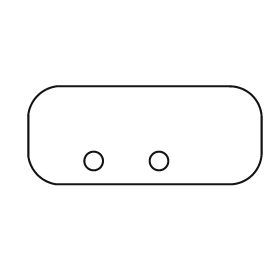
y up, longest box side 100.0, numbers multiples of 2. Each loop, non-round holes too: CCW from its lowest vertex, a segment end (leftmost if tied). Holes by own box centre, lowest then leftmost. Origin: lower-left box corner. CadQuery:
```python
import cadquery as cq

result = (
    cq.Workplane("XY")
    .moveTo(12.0, 0.0)
    .lineTo(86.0, 0.0)
    .threePointArc((96.0, 4.0), (100.0, 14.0))
    .lineTo(100.0, 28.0)
    .threePointArc((96.0, 38.0), (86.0, 42.0))
    .lineTo(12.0, 42.0)
    .threePointArc((4.0, 38.0), (0.0, 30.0))
    .lineTo(0.0, 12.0)
    .threePointArc((4.0, 4.0), (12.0, 0.0))
    .close()
    .moveTo(28.0, 10.0)
    .circle(4.0)
    .moveTo(56.0, 10.0)
    .circle(4.0)
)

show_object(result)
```